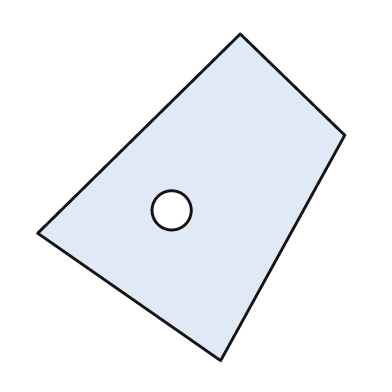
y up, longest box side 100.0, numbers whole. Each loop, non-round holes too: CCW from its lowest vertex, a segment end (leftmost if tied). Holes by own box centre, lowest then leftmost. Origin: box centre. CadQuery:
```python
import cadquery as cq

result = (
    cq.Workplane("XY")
    .moveTo(9.0, -50.0)
    .lineTo(47.0, 19.0)
    .lineTo(15.0, 50.0)
    .lineTo(-47.0, -11.0)
    .close()
    .moveTo(-6.0, -4.0)
    .circle(6.0)
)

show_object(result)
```